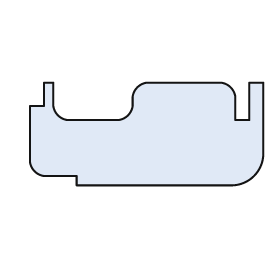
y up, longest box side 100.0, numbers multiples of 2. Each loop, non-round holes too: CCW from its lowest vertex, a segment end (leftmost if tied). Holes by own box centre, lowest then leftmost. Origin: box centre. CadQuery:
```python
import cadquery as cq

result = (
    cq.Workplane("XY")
    .moveTo(-30.0, -22.0)
    .lineTo(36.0, -22.0)
    .threePointArc((46.0, -18.0), (50.0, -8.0))
    .lineTo(50.0, 22.0)
    .lineTo(44.0, 22.0)
    .lineTo(44.0, 6.0)
    .lineTo(38.0, 6.0)
    .lineTo(38.0, 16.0)
    .threePointArc((36.0, 20.0), (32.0, 22.0))
    .lineTo(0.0, 22.0)
    .threePointArc((-4.0, 20.0), (-6.0, 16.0))
    .lineTo(-6.0, 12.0)
    .threePointArc((-8.0, 8.0), (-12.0, 6.0))
    .lineTo(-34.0, 6.0)
    .threePointArc((-38.0, 8.0), (-40.0, 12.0))
    .lineTo(-40.0, 22.0)
    .lineTo(-44.0, 22.0)
    .lineTo(-44.0, 12.0)
    .lineTo(-50.0, 12.0)
    .lineTo(-50.0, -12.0)
    .threePointArc((-48.0, -16.0), (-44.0, -18.0))
    .lineTo(-30.0, -18.0)
    .close()
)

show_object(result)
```